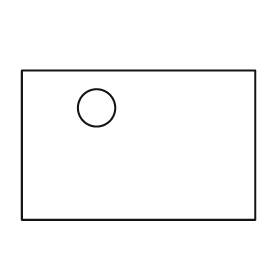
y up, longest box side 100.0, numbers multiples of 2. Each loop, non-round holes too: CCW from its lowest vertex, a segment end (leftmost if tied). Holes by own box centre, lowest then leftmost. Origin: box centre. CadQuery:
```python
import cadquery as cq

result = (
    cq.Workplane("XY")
    .moveTo(-50.0, -32.0)
    .lineTo(50.0, -32.0)
    .lineTo(50.0, 32.0)
    .lineTo(-50.0, 32.0)
    .close()
    .moveTo(-18.0, 16.0)
    .circle(8.0)
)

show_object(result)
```